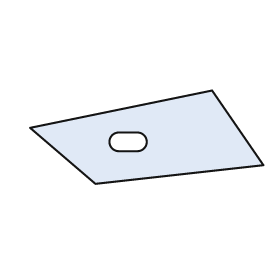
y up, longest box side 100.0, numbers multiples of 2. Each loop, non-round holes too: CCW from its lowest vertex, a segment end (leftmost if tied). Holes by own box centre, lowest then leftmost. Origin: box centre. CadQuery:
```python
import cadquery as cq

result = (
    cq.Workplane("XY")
    .moveTo(-22.0, -20.0)
    .lineTo(50.0, -12.0)
    .lineTo(28.0, 20.0)
    .lineTo(-50.0, 4.0)
    .close()
    .moveTo(-12.0, -6.0)
    .lineTo(-4.0, -6.0)
    .threePointArc((0.0, -2.0), (-4.0, 2.0))
    .lineTo(-12.0, 2.0)
    .threePointArc((-16.0, -2.0), (-12.0, -6.0))
    .close()
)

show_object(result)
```